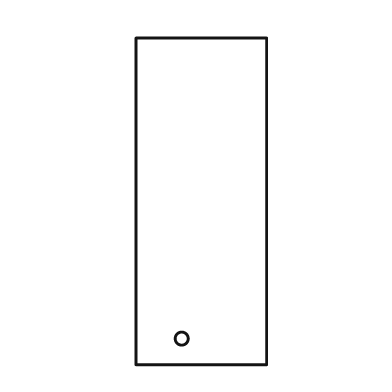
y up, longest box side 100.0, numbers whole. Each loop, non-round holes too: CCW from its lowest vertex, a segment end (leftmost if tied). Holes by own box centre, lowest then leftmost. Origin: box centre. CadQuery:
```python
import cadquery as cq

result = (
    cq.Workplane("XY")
    .moveTo(-20.0, -50.0)
    .lineTo(20.0, -50.0)
    .lineTo(20.0, 50.0)
    .lineTo(-20.0, 50.0)
    .close()
    .moveTo(-6.0, -42.0)
    .circle(2.0)
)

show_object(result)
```